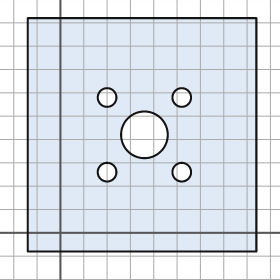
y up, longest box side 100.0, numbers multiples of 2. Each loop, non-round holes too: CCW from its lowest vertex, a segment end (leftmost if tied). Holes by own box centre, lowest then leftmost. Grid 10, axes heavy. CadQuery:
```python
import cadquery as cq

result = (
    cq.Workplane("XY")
    .moveTo(-14.0, -8.0)
    .lineTo(84.0, -8.0)
    .lineTo(84.0, 92.0)
    .lineTo(-14.0, 92.0)
    .close()
    .moveTo(20.0, 26.0)
    .circle(4.0)
    .moveTo(52.0, 26.0)
    .circle(4.0)
    .moveTo(36.0, 42.0)
    .circle(10.0)
    .moveTo(20.0, 58.0)
    .circle(4.0)
    .moveTo(52.0, 58.0)
    .circle(4.0)
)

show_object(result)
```